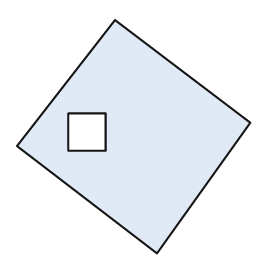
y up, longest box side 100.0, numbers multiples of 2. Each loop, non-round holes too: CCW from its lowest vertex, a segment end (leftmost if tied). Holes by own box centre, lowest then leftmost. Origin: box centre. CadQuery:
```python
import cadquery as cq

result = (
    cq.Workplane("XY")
    .moveTo(10.0, -50.0)
    .lineTo(50.0, 6.0)
    .lineTo(-8.0, 50.0)
    .lineTo(-50.0, -4.0)
    .close()
    .moveTo(-28.0, -6.0)
    .lineTo(-12.0, -6.0)
    .lineTo(-12.0, 10.0)
    .lineTo(-28.0, 10.0)
    .close()
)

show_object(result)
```